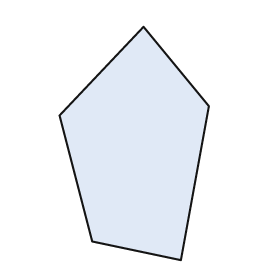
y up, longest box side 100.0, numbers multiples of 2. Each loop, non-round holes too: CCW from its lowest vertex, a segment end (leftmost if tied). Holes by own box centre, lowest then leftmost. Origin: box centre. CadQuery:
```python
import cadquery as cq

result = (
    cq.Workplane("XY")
    .moveTo(20.0, -50.0)
    .lineTo(32.0, 16.0)
    .lineTo(4.0, 50.0)
    .lineTo(-32.0, 12.0)
    .lineTo(-18.0, -42.0)
    .close()
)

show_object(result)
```